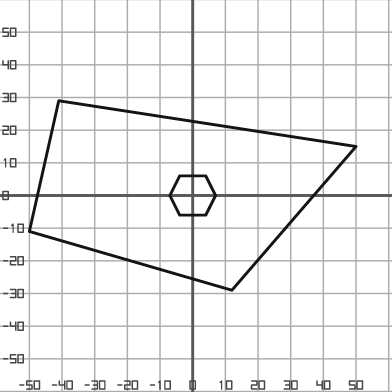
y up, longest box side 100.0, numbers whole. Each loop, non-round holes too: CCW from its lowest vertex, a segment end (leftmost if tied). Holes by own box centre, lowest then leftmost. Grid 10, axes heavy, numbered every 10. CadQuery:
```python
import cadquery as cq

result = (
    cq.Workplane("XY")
    .moveTo(12.0, -29.0)
    .lineTo(50.0, 15.0)
    .lineTo(-41.0, 29.0)
    .lineTo(-50.0, -11.0)
    .close()
    .moveTo(-4.0, -6.0)
    .lineTo(4.0, -6.0)
    .lineTo(7.0, 0.0)
    .lineTo(4.0, 6.0)
    .lineTo(-4.0, 6.0)
    .lineTo(-7.0, 0.0)
    .close()
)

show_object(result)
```